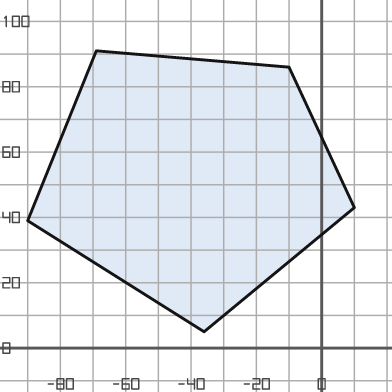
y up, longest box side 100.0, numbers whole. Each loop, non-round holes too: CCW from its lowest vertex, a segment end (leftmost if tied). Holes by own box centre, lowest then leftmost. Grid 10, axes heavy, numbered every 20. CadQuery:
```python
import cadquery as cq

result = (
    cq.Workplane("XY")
    .moveTo(-36.0, 5.0)
    .lineTo(10.0, 43.0)
    .lineTo(-10.0, 86.0)
    .lineTo(-69.0, 91.0)
    .lineTo(-90.0, 39.0)
    .close()
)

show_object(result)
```